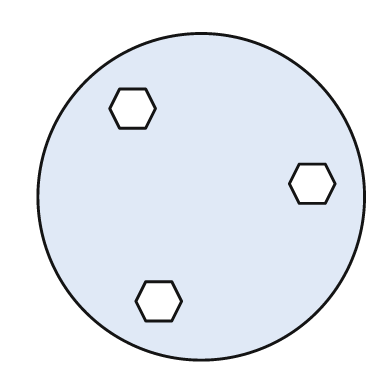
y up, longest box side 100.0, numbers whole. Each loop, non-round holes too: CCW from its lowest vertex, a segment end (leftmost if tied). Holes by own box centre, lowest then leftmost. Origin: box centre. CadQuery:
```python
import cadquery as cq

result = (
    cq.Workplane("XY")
    .moveTo(0.0, 0.0)
    .circle(50.0)
    .moveTo(-17.0, -38.0)
    .lineTo(-9.0, -38.0)
    .lineTo(-6.0, -32.0)
    .lineTo(-9.0, -26.0)
    .lineTo(-17.0, -26.0)
    .lineTo(-20.0, -32.0)
    .close()
    .moveTo(30.0, -2.0)
    .lineTo(38.0, -2.0)
    .lineTo(41.0, 4.0)
    .lineTo(38.0, 10.0)
    .lineTo(30.0, 10.0)
    .lineTo(27.0, 4.0)
    .close()
    .moveTo(-25.0, 21.0)
    .lineTo(-17.0, 21.0)
    .lineTo(-14.0, 27.0)
    .lineTo(-17.0, 33.0)
    .lineTo(-25.0, 33.0)
    .lineTo(-28.0, 27.0)
    .close()
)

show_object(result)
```